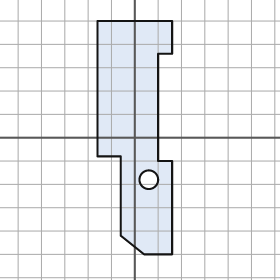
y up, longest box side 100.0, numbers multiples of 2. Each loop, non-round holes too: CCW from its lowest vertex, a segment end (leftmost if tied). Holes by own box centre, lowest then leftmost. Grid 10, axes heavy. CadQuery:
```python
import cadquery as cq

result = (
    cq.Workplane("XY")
    .moveTo(4.0, -50.0)
    .lineTo(16.0, -50.0)
    .lineTo(16.0, -10.0)
    .lineTo(10.0, -10.0)
    .lineTo(10.0, 36.0)
    .lineTo(16.0, 36.0)
    .lineTo(16.0, 50.0)
    .lineTo(-16.0, 50.0)
    .lineTo(-16.0, -8.0)
    .lineTo(-6.0, -8.0)
    .lineTo(-6.0, -42.0)
    .close()
    .moveTo(6.0, -18.0)
    .circle(4.0)
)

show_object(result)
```